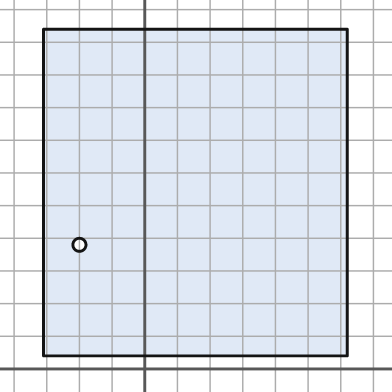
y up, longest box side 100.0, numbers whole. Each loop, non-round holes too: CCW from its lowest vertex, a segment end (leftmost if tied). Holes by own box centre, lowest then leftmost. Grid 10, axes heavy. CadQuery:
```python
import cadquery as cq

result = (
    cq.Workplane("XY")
    .moveTo(-31.0, 4.0)
    .lineTo(62.0, 4.0)
    .lineTo(62.0, 104.0)
    .lineTo(-31.0, 104.0)
    .close()
    .moveTo(-20.0, 38.0)
    .circle(2.0)
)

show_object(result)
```